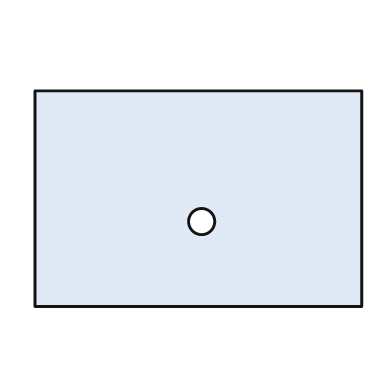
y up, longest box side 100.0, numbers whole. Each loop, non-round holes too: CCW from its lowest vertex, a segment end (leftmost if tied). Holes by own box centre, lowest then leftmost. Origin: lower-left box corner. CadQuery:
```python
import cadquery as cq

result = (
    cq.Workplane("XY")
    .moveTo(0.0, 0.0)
    .lineTo(100.0, 0.0)
    .lineTo(100.0, 66.0)
    .lineTo(0.0, 66.0)
    .close()
    .moveTo(51.0, 26.0)
    .circle(4.0)
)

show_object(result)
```